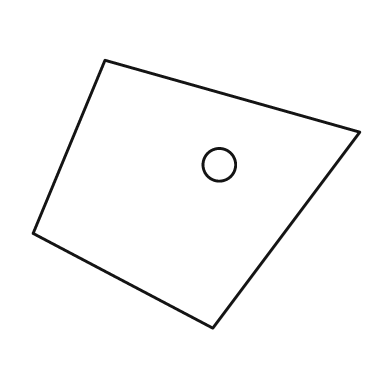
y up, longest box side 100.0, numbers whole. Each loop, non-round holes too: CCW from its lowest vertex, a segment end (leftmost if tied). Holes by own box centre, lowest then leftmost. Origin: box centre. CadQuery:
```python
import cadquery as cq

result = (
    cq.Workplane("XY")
    .moveTo(5.0, -41.0)
    .lineTo(50.0, 19.0)
    .lineTo(-28.0, 41.0)
    .lineTo(-50.0, -12.0)
    .close()
    .moveTo(7.0, 9.0)
    .circle(5.0)
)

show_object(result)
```